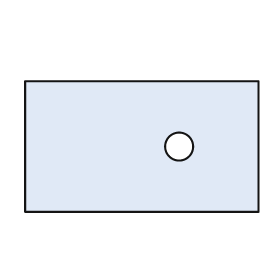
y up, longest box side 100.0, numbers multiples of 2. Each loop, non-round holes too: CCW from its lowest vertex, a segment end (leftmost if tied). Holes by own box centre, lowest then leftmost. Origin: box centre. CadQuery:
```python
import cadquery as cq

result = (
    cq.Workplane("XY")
    .moveTo(-50.0, -28.0)
    .lineTo(50.0, -28.0)
    .lineTo(50.0, 28.0)
    .lineTo(-50.0, 28.0)
    .close()
    .moveTo(16.0, 0.0)
    .circle(6.0)
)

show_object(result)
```